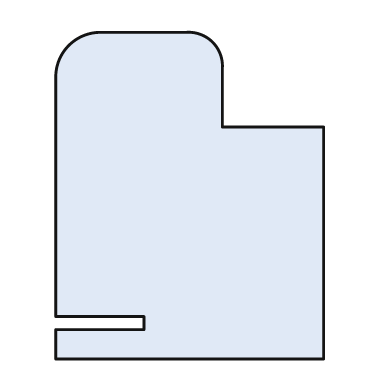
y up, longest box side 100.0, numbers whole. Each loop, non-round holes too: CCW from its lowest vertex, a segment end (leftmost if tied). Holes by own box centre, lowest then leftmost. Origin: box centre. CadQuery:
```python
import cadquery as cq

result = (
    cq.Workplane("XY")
    .moveTo(-41.0, -50.0)
    .lineTo(41.0, -50.0)
    .lineTo(41.0, 21.0)
    .lineTo(10.0, 21.0)
    .lineTo(10.0, 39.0)
    .threePointArc((7.0, 47.0), (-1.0, 50.0))
    .lineTo(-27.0, 50.0)
    .threePointArc((-37.0, 46.0), (-41.0, 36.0))
    .lineTo(-41.0, -37.0)
    .lineTo(-14.0, -37.0)
    .lineTo(-14.0, -41.0)
    .lineTo(-41.0, -41.0)
    .close()
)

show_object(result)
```